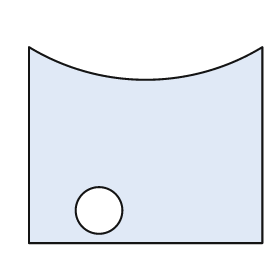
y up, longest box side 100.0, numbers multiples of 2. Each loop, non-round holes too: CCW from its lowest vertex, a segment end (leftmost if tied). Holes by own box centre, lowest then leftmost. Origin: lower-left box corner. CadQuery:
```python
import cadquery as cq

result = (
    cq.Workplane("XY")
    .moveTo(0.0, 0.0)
    .lineTo(100.0, 0.0)
    .lineTo(100.0, 84.0)
    .threePointArc((50.0, 70.0), (0.0, 84.0))
    .close()
    .moveTo(30.0, 14.0)
    .circle(10.0)
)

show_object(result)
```